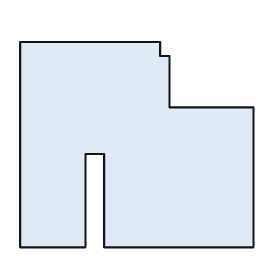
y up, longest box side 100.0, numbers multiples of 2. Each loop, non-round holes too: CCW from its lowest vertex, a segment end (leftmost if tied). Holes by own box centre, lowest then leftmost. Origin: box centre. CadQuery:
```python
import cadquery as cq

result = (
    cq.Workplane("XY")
    .moveTo(-50.0, -44.0)
    .lineTo(-22.0, -44.0)
    .lineTo(-22.0, -4.0)
    .lineTo(-14.0, -4.0)
    .lineTo(-14.0, -44.0)
    .lineTo(50.0, -44.0)
    .lineTo(50.0, 16.0)
    .lineTo(14.0, 16.0)
    .lineTo(14.0, 38.0)
    .lineTo(10.0, 38.0)
    .lineTo(10.0, 44.0)
    .lineTo(-50.0, 44.0)
    .close()
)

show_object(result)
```